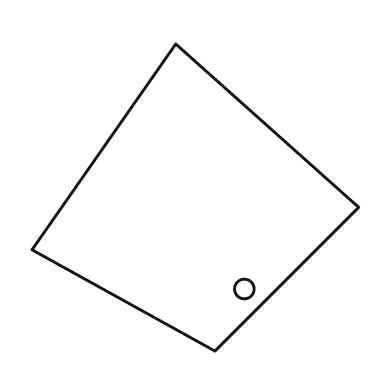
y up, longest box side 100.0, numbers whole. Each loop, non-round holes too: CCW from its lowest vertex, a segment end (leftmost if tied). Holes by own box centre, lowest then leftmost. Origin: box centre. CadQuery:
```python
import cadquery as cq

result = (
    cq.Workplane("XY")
    .moveTo(6.0, -47.0)
    .lineTo(50.0, -3.0)
    .lineTo(-6.0, 47.0)
    .lineTo(-50.0, -16.0)
    .close()
    .moveTo(15.0, -28.0)
    .circle(3.0)
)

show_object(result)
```